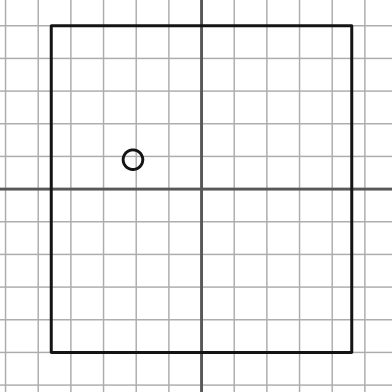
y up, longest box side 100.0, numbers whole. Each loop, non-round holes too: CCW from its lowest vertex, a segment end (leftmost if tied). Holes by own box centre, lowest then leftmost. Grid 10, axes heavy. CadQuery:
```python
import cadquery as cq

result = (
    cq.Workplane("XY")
    .moveTo(-46.0, -50.0)
    .lineTo(46.0, -50.0)
    .lineTo(46.0, 50.0)
    .lineTo(-46.0, 50.0)
    .close()
    .moveTo(-21.0, 9.0)
    .circle(3.0)
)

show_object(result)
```